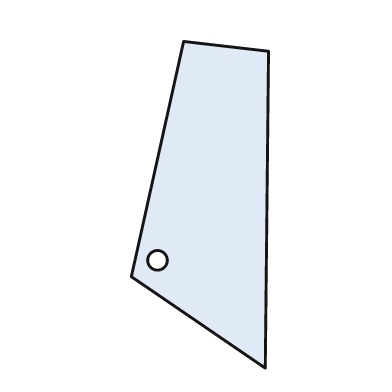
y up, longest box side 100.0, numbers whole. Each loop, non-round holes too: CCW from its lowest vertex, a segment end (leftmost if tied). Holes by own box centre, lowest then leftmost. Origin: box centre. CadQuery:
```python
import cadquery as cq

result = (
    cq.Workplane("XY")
    .moveTo(20.0, -50.0)
    .lineTo(21.0, 47.0)
    .lineTo(-5.0, 50.0)
    .lineTo(-21.0, -22.0)
    .close()
    .moveTo(-13.0, -17.0)
    .circle(3.0)
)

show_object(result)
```